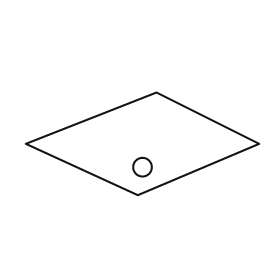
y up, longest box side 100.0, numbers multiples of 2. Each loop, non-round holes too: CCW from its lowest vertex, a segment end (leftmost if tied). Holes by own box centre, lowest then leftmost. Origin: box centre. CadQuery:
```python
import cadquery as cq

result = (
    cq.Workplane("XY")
    .moveTo(-2.0, -22.0)
    .lineTo(50.0, 0.0)
    .lineTo(6.0, 22.0)
    .lineTo(-50.0, 0.0)
    .close()
    .moveTo(0.0, -10.0)
    .circle(4.0)
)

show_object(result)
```